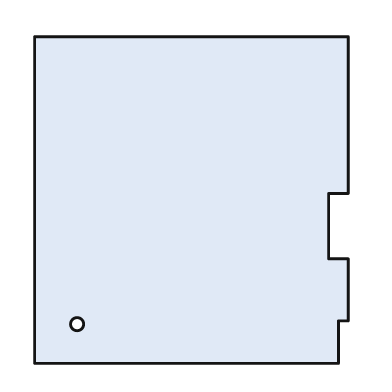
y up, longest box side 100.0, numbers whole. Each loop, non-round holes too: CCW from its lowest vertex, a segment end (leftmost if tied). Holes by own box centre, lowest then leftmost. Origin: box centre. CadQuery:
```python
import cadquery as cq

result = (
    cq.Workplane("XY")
    .moveTo(-48.0, -50.0)
    .lineTo(45.0, -50.0)
    .lineTo(45.0, -37.0)
    .lineTo(48.0, -37.0)
    .lineTo(48.0, -18.0)
    .lineTo(42.0, -18.0)
    .lineTo(42.0, 2.0)
    .lineTo(48.0, 2.0)
    .lineTo(48.0, 50.0)
    .lineTo(-48.0, 50.0)
    .close()
    .moveTo(-35.0, -38.0)
    .circle(2.0)
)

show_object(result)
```